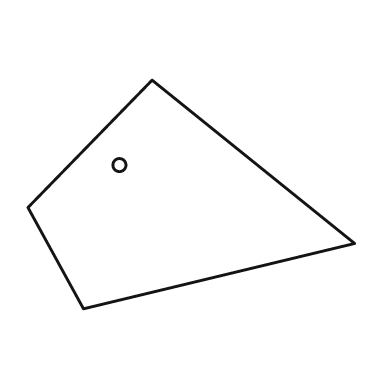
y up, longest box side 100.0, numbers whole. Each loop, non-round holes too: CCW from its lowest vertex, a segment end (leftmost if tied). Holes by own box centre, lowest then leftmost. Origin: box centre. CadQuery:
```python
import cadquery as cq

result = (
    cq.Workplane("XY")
    .moveTo(-33.0, -35.0)
    .lineTo(50.0, -15.0)
    .lineTo(-12.0, 35.0)
    .lineTo(-50.0, -4.0)
    .close()
    .moveTo(-22.0, 9.0)
    .circle(2.0)
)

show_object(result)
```